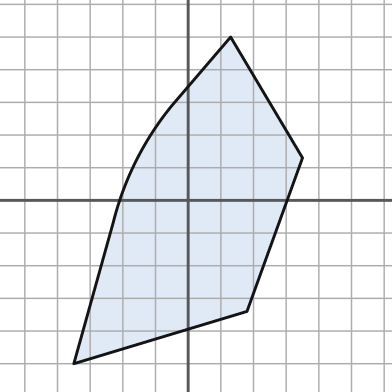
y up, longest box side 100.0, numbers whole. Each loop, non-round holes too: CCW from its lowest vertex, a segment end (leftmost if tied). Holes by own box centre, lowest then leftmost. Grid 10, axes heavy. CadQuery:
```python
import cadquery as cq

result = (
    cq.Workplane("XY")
    .moveTo(-35.0, -50.0)
    .lineTo(18.0, -34.0)
    .lineTo(35.0, 13.0)
    .lineTo(13.0, 50.0)
    .lineTo(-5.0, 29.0)
    .threePointArc((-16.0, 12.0), (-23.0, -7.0))
    .close()
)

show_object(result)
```